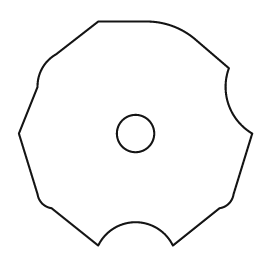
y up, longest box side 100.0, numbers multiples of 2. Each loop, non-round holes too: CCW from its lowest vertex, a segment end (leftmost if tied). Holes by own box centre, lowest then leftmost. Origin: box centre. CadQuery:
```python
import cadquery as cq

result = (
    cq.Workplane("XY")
    .moveTo(-16.0, -48.0)
    .threePointArc((0.0, -38.0), (16.0, -48.0))
    .lineTo(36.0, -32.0)
    .threePointArc((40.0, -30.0), (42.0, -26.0))
    .lineTo(50.0, 0.0)
    .threePointArc((40.0, 12.0), (40.0, 28.0))
    .lineTo(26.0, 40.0)
    .threePointArc((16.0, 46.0), (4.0, 48.0))
    .lineTo(-16.0, 48.0)
    .lineTo(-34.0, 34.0)
    .threePointArc((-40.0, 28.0), (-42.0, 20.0))
    .lineTo(-50.0, 0.0)
    .lineTo(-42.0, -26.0)
    .threePointArc((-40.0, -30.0), (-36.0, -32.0))
    .close()
    .moveTo(0.0, 0.0)
    .circle(8.0)
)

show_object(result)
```